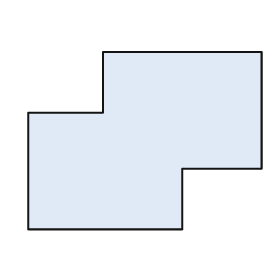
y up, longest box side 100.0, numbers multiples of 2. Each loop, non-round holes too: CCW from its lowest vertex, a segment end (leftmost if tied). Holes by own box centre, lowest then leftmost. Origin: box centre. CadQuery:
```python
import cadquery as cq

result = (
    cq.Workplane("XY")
    .moveTo(-50.0, -38.0)
    .lineTo(16.0, -38.0)
    .lineTo(16.0, -12.0)
    .lineTo(50.0, -12.0)
    .lineTo(50.0, 38.0)
    .lineTo(-18.0, 38.0)
    .lineTo(-18.0, 12.0)
    .lineTo(-50.0, 12.0)
    .close()
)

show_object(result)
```